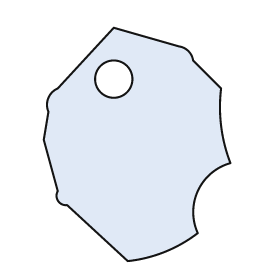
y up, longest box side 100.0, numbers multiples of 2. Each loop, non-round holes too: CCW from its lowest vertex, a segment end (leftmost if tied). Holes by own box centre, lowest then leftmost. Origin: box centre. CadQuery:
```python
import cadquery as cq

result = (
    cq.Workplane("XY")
    .moveTo(-4.0, -50.0)
    .threePointArc((12.0, -46.0), (26.0, -38.0))
    .threePointArc((26.0, -20.0), (40.0, -8.0))
    .threePointArc((36.0, 8.0), (36.0, 24.0))
    .lineTo(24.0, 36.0)
    .threePointArc((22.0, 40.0), (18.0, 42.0))
    .lineTo(-10.0, 50.0)
    .lineTo(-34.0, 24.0)
    .threePointArc((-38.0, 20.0), (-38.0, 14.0))
    .lineTo(-40.0, 2.0)
    .lineTo(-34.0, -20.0)
    .threePointArc((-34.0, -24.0), (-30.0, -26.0))
    .close()
    .moveTo(-10.0, 28.0)
    .circle(8.0)
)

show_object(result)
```